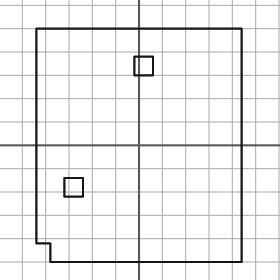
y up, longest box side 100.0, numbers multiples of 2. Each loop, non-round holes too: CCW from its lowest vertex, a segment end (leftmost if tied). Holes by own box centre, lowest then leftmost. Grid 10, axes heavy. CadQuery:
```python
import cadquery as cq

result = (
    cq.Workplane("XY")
    .moveTo(-38.0, -50.0)
    .lineTo(44.0, -50.0)
    .lineTo(44.0, 50.0)
    .lineTo(-44.0, 50.0)
    .lineTo(-44.0, -42.0)
    .lineTo(-38.0, -42.0)
    .close()
    .moveTo(-32.0, -22.0)
    .lineTo(-24.0, -22.0)
    .lineTo(-24.0, -14.0)
    .lineTo(-32.0, -14.0)
    .close()
    .moveTo(-2.0, 30.0)
    .lineTo(6.0, 30.0)
    .lineTo(6.0, 38.0)
    .lineTo(-2.0, 38.0)
    .close()
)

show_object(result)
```